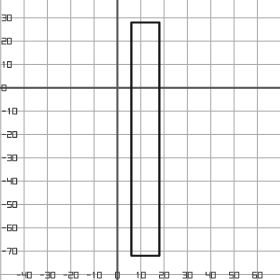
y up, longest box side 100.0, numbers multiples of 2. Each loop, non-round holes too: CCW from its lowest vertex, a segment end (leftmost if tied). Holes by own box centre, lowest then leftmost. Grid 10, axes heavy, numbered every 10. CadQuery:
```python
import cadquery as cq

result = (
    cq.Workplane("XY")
    .moveTo(6.0, -72.0)
    .lineTo(18.0, -72.0)
    .lineTo(18.0, 28.0)
    .lineTo(6.0, 28.0)
    .close()
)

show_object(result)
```